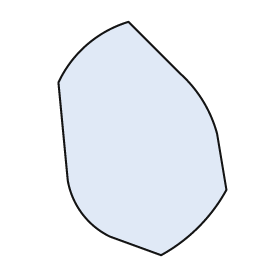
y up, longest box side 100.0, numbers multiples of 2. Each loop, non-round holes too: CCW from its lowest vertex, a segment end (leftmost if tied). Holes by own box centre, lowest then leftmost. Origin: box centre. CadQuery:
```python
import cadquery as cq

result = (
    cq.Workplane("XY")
    .moveTo(8.0, -50.0)
    .threePointArc((24.0, -38.0), (36.0, -22.0))
    .lineTo(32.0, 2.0)
    .threePointArc((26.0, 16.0), (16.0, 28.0))
    .lineTo(-6.0, 50.0)
    .threePointArc((-24.0, 40.0), (-36.0, 24.0))
    .lineTo(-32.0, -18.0)
    .threePointArc((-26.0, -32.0), (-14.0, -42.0))
    .close()
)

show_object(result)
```